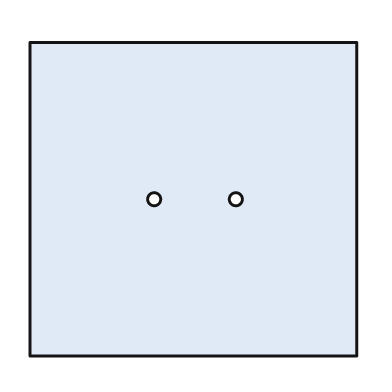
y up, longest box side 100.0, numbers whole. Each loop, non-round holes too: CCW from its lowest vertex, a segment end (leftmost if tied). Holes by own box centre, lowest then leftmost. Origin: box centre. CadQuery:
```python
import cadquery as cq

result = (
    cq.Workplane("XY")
    .moveTo(-50.0, -48.0)
    .lineTo(50.0, -48.0)
    .lineTo(50.0, 48.0)
    .lineTo(-50.0, 48.0)
    .close()
    .moveTo(-12.0, 0.0)
    .circle(2.0)
    .moveTo(13.0, 0.0)
    .circle(2.0)
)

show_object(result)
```